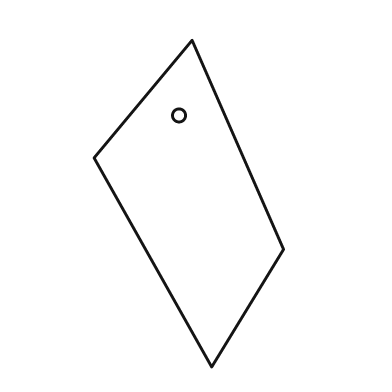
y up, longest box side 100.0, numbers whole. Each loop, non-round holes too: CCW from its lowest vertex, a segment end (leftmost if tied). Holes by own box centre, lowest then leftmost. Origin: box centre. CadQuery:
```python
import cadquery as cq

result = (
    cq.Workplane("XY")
    .moveTo(7.0, -50.0)
    .lineTo(29.0, -14.0)
    .lineTo(1.0, 50.0)
    .lineTo(-29.0, 14.0)
    .close()
    .moveTo(-3.0, 27.0)
    .circle(2.0)
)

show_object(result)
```